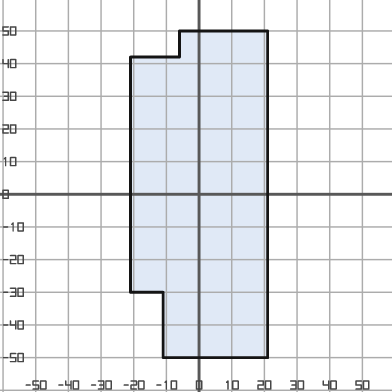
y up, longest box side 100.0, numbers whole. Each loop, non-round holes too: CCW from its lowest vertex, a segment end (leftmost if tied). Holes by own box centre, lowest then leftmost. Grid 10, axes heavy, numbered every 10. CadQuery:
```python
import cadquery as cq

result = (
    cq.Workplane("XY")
    .moveTo(-11.0, -50.0)
    .lineTo(21.0, -50.0)
    .lineTo(21.0, 50.0)
    .lineTo(-6.0, 50.0)
    .lineTo(-6.0, 42.0)
    .lineTo(-21.0, 42.0)
    .lineTo(-21.0, -30.0)
    .lineTo(-11.0, -30.0)
    .close()
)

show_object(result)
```